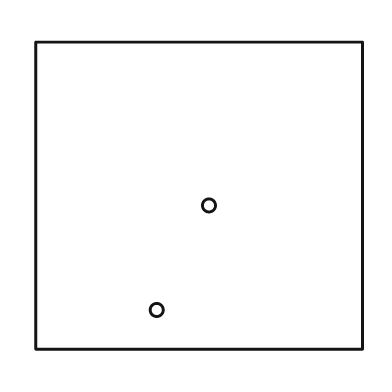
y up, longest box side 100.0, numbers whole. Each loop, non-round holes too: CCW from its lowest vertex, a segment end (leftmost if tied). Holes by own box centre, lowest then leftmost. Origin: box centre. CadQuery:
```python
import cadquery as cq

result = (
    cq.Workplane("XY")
    .moveTo(-50.0, -47.0)
    .lineTo(50.0, -47.0)
    .lineTo(50.0, 47.0)
    .lineTo(-50.0, 47.0)
    .close()
    .moveTo(-13.0, -35.0)
    .circle(2.0)
    .moveTo(3.0, -3.0)
    .circle(2.0)
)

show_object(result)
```